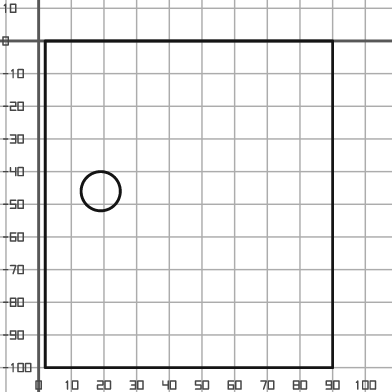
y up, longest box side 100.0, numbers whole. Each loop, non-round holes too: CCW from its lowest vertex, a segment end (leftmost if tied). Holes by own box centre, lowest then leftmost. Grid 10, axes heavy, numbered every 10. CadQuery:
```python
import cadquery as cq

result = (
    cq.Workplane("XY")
    .moveTo(2.0, -100.0)
    .lineTo(90.0, -100.0)
    .lineTo(90.0, 0.0)
    .lineTo(2.0, 0.0)
    .close()
    .moveTo(19.0, -46.0)
    .circle(6.0)
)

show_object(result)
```